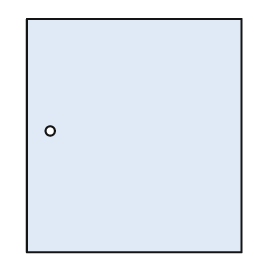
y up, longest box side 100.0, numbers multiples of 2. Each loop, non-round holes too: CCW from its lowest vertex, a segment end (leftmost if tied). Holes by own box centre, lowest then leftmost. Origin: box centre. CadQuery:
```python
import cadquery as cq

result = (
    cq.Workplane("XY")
    .moveTo(-46.0, -50.0)
    .lineTo(46.0, -50.0)
    .lineTo(46.0, 50.0)
    .lineTo(-46.0, 50.0)
    .close()
    .moveTo(-36.0, 2.0)
    .circle(2.0)
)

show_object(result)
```